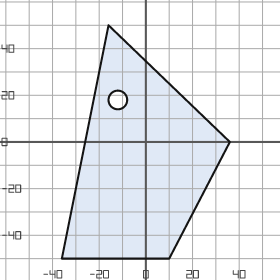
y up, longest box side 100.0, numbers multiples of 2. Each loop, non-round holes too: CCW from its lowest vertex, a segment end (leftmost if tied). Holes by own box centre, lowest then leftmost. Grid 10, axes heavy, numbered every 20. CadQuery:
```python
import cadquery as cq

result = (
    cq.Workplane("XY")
    .moveTo(-36.0, -50.0)
    .lineTo(10.0, -50.0)
    .lineTo(36.0, 0.0)
    .lineTo(-16.0, 50.0)
    .close()
    .moveTo(-12.0, 18.0)
    .circle(4.0)
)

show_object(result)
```